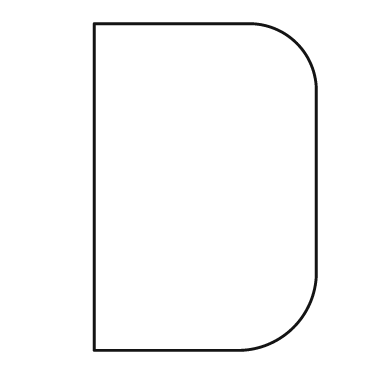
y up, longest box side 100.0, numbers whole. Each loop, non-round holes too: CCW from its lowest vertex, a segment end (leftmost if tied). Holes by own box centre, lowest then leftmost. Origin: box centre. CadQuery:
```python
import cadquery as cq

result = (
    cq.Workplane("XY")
    .moveTo(-34.0, -50.0)
    .lineTo(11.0, -50.0)
    .threePointArc((27.0, -43.0), (34.0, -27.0))
    .lineTo(34.0, 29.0)
    .threePointArc((28.0, 44.0), (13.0, 50.0))
    .lineTo(-34.0, 50.0)
    .close()
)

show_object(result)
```